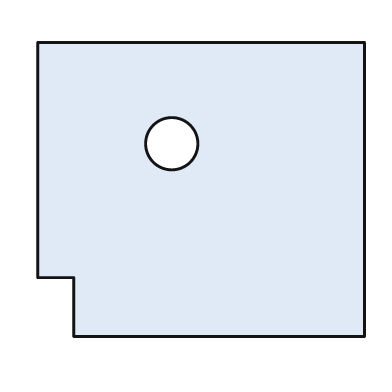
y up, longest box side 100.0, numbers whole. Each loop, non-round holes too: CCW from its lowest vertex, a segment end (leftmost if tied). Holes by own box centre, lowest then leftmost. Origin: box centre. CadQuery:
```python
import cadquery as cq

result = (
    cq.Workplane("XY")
    .moveTo(-39.0, -45.0)
    .lineTo(50.0, -45.0)
    .lineTo(50.0, 45.0)
    .lineTo(-50.0, 45.0)
    .lineTo(-50.0, -27.0)
    .lineTo(-39.0, -27.0)
    .close()
    .moveTo(-9.0, 14.0)
    .circle(8.0)
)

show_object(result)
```